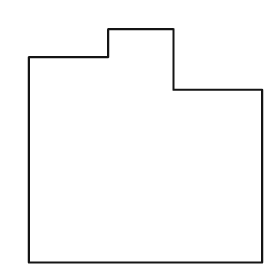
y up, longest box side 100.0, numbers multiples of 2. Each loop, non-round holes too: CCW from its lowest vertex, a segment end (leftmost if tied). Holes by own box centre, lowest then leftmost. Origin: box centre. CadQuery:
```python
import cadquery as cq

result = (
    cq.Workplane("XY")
    .moveTo(-50.0, -50.0)
    .lineTo(50.0, -50.0)
    .lineTo(50.0, 24.0)
    .lineTo(12.0, 24.0)
    .lineTo(12.0, 50.0)
    .lineTo(-16.0, 50.0)
    .lineTo(-16.0, 38.0)
    .lineTo(-50.0, 38.0)
    .close()
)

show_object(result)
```